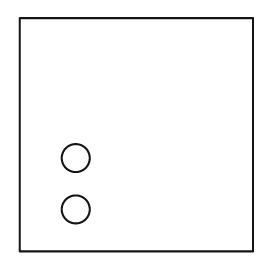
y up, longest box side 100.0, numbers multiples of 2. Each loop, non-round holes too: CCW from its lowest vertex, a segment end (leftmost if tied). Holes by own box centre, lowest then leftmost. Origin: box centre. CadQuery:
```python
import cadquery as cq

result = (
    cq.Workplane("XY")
    .moveTo(-50.0, -50.0)
    .lineTo(50.0, -50.0)
    .lineTo(50.0, 50.0)
    .lineTo(-50.0, 50.0)
    .close()
    .moveTo(-26.0, -32.0)
    .circle(6.0)
    .moveTo(-26.0, -10.0)
    .circle(6.0)
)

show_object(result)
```